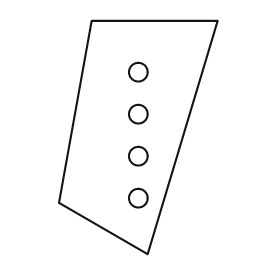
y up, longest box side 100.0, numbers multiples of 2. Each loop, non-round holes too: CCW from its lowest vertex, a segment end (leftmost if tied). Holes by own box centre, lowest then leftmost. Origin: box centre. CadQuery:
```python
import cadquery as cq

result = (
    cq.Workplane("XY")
    .moveTo(4.0, -50.0)
    .lineTo(34.0, 50.0)
    .lineTo(-20.0, 50.0)
    .lineTo(-34.0, -28.0)
    .close()
    .moveTo(0.0, -26.0)
    .circle(4.0)
    .moveTo(0.0, -8.0)
    .circle(4.0)
    .moveTo(0.0, 10.0)
    .circle(4.0)
    .moveTo(0.0, 28.0)
    .circle(4.0)
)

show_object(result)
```